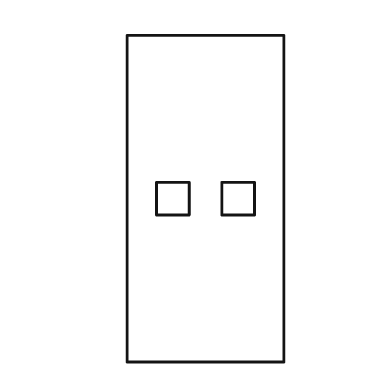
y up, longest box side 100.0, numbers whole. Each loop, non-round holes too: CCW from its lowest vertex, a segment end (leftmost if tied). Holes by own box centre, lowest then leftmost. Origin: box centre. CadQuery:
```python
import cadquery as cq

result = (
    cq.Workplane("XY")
    .moveTo(-24.0, -50.0)
    .lineTo(24.0, -50.0)
    .lineTo(24.0, 50.0)
    .lineTo(-24.0, 50.0)
    .close()
    .moveTo(-15.0, -5.0)
    .lineTo(-5.0, -5.0)
    .lineTo(-5.0, 5.0)
    .lineTo(-15.0, 5.0)
    .close()
    .moveTo(5.0, -5.0)
    .lineTo(15.0, -5.0)
    .lineTo(15.0, 5.0)
    .lineTo(5.0, 5.0)
    .close()
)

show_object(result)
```